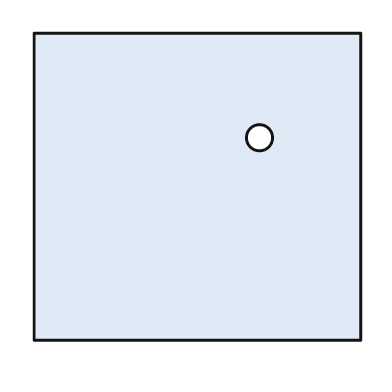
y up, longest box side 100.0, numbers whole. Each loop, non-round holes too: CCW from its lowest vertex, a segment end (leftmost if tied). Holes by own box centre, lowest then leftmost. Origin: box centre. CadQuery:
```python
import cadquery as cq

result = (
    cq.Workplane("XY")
    .moveTo(-50.0, -47.0)
    .lineTo(50.0, -47.0)
    .lineTo(50.0, 47.0)
    .lineTo(-50.0, 47.0)
    .close()
    .moveTo(19.0, 15.0)
    .circle(4.0)
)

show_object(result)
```